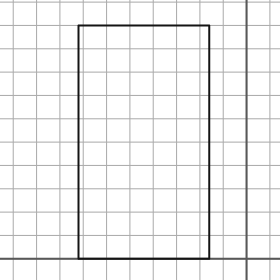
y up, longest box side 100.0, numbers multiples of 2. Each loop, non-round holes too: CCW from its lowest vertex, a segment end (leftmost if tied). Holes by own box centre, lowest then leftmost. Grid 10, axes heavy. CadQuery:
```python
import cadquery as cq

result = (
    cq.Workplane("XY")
    .moveTo(-72.0, 0.0)
    .lineTo(-16.0, 0.0)
    .lineTo(-16.0, 100.0)
    .lineTo(-72.0, 100.0)
    .close()
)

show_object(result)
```